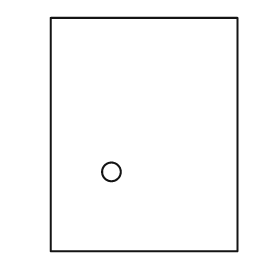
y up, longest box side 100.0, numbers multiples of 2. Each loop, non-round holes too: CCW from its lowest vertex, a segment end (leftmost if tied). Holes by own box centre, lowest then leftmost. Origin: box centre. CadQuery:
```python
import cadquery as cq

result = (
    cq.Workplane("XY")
    .moveTo(-40.0, -50.0)
    .lineTo(40.0, -50.0)
    .lineTo(40.0, 50.0)
    .lineTo(-40.0, 50.0)
    .close()
    .moveTo(-14.0, -16.0)
    .circle(4.0)
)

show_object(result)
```